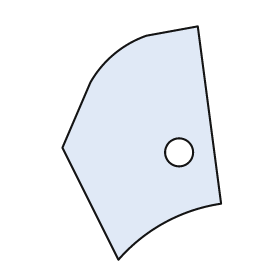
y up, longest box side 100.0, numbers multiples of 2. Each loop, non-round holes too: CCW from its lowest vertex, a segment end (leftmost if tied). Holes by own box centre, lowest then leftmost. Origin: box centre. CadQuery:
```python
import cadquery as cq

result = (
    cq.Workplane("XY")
    .moveTo(-10.0, -50.0)
    .threePointArc((10.0, -34.0), (34.0, -26.0))
    .lineTo(24.0, 50.0)
    .lineTo(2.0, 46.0)
    .threePointArc((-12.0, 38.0), (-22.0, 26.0))
    .lineTo(-34.0, -2.0)
    .close()
    .moveTo(16.0, -4.0)
    .circle(6.0)
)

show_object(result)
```